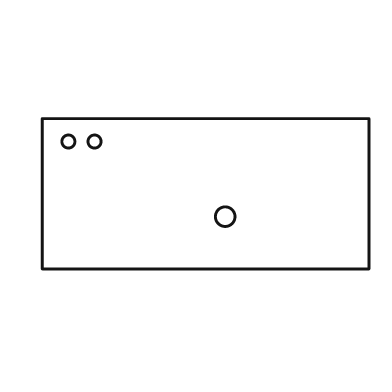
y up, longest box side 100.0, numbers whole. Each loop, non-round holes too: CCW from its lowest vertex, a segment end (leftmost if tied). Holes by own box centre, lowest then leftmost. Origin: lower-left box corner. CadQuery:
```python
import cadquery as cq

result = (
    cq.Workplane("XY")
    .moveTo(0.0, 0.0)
    .lineTo(100.0, 0.0)
    .lineTo(100.0, 46.0)
    .lineTo(0.0, 46.0)
    .close()
    .moveTo(56.0, 16.0)
    .circle(3.0)
    .moveTo(8.0, 39.0)
    .circle(2.0)
    .moveTo(16.0, 39.0)
    .circle(2.0)
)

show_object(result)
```